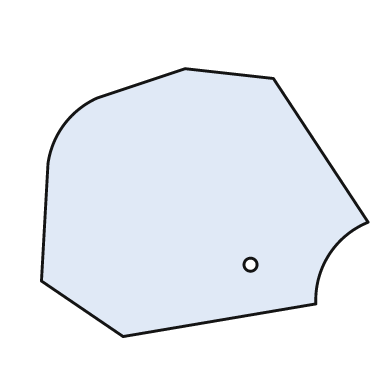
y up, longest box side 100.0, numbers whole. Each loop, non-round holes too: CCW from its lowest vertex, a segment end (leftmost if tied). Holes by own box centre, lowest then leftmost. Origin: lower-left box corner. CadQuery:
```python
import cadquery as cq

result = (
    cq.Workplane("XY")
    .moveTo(25.0, 0.0)
    .lineTo(84.0, 10.0)
    .threePointArc((88.0, 25.0), (100.0, 35.0))
    .lineTo(71.0, 79.0)
    .lineTo(44.0, 82.0)
    .lineTo(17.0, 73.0)
    .threePointArc((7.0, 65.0), (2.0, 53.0))
    .lineTo(0.0, 17.0)
    .close()
    .moveTo(64.0, 22.0)
    .circle(2.0)
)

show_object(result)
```